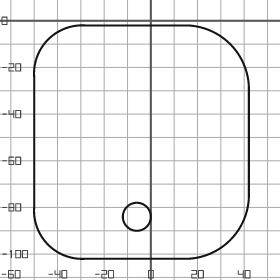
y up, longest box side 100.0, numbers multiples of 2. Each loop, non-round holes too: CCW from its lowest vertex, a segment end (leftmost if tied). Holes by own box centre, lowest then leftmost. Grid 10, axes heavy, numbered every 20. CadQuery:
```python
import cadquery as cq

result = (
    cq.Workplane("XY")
    .moveTo(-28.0, -102.0)
    .lineTo(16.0, -102.0)
    .threePointArc((34.0, -94.0), (42.0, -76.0))
    .lineTo(42.0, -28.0)
    .threePointArc((34.0, -10.0), (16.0, -2.0))
    .lineTo(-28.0, -2.0)
    .threePointArc((-44.0, -8.0), (-50.0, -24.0))
    .lineTo(-50.0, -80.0)
    .threePointArc((-44.0, -96.0), (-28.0, -102.0))
    .close()
    .moveTo(-6.0, -84.0)
    .circle(6.0)
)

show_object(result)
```